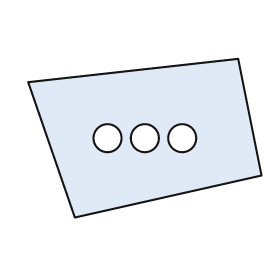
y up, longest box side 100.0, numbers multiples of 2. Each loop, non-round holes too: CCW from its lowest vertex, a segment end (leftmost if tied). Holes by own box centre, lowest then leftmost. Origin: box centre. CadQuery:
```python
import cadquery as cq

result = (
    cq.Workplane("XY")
    .moveTo(-30.0, -34.0)
    .lineTo(50.0, -16.0)
    .lineTo(40.0, 34.0)
    .lineTo(-50.0, 24.0)
    .close()
    .moveTo(-16.0, 0.0)
    .circle(6.0)
    .moveTo(0.0, 0.0)
    .circle(6.0)
    .moveTo(16.0, 0.0)
    .circle(6.0)
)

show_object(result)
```